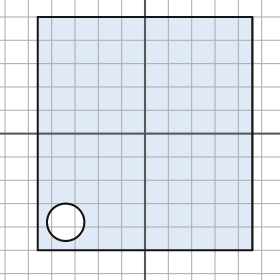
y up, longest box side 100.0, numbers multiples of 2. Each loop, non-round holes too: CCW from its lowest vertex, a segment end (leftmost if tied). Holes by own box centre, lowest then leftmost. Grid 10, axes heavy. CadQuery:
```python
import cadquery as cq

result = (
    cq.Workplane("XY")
    .moveTo(-46.0, -50.0)
    .lineTo(46.0, -50.0)
    .lineTo(46.0, 50.0)
    .lineTo(-46.0, 50.0)
    .close()
    .moveTo(-34.0, -38.0)
    .circle(8.0)
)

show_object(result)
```